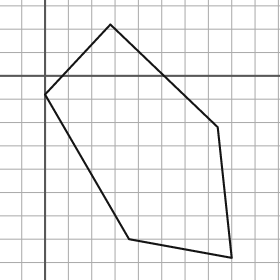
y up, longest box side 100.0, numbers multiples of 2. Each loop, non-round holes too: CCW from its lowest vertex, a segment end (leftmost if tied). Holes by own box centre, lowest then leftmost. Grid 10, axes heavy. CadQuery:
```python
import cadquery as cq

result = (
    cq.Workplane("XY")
    .moveTo(80.0, -78.0)
    .lineTo(74.0, -22.0)
    .lineTo(28.0, 22.0)
    .lineTo(0.0, -8.0)
    .lineTo(36.0, -70.0)
    .close()
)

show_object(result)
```